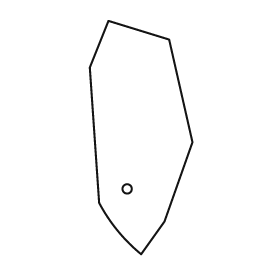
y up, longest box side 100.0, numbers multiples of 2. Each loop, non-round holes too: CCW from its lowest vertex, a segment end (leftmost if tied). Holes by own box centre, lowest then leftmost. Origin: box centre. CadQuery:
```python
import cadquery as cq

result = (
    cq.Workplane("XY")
    .moveTo(0.0, -50.0)
    .lineTo(10.0, -36.0)
    .lineTo(22.0, -2.0)
    .lineTo(12.0, 42.0)
    .lineTo(-14.0, 50.0)
    .lineTo(-22.0, 30.0)
    .lineTo(-18.0, -28.0)
    .threePointArc((-10.0, -40.0), (0.0, -50.0))
    .close()
    .moveTo(-6.0, -22.0)
    .circle(2.0)
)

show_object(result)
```